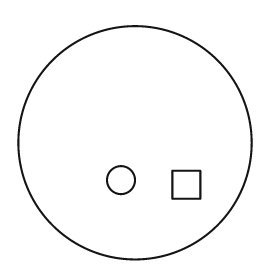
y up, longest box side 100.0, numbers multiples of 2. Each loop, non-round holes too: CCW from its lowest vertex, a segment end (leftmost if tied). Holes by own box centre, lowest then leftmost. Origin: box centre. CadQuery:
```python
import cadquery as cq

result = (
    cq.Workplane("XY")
    .moveTo(0.0, 0.0)
    .circle(50.0)
    .moveTo(16.0, -24.0)
    .lineTo(28.0, -24.0)
    .lineTo(28.0, -12.0)
    .lineTo(16.0, -12.0)
    .close()
    .moveTo(-6.0, -16.0)
    .circle(6.0)
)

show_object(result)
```